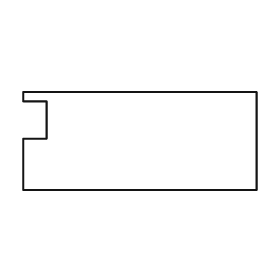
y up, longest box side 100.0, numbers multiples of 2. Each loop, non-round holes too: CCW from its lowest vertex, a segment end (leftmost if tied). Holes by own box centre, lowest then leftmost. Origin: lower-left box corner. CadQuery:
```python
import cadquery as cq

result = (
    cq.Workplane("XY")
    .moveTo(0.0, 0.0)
    .lineTo(100.0, 0.0)
    .lineTo(100.0, 42.0)
    .lineTo(0.0, 42.0)
    .lineTo(0.0, 38.0)
    .lineTo(10.0, 38.0)
    .lineTo(10.0, 22.0)
    .lineTo(0.0, 22.0)
    .close()
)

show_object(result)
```